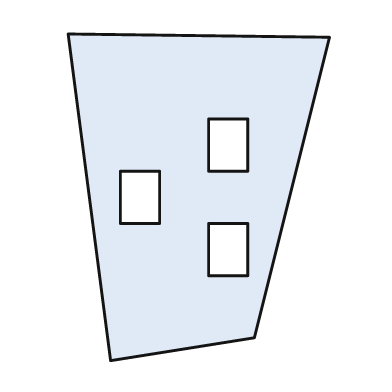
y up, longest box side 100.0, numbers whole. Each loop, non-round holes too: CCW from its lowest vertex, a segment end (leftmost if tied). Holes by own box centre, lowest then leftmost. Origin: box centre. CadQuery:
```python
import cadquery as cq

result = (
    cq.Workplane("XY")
    .moveTo(-27.0, -50.0)
    .lineTo(17.0, -43.0)
    .lineTo(40.0, 49.0)
    .lineTo(-40.0, 50.0)
    .close()
    .moveTo(3.0, -24.0)
    .lineTo(15.0, -24.0)
    .lineTo(15.0, -8.0)
    .lineTo(3.0, -8.0)
    .close()
    .moveTo(-24.0, -8.0)
    .lineTo(-12.0, -8.0)
    .lineTo(-12.0, 8.0)
    .lineTo(-24.0, 8.0)
    .close()
    .moveTo(3.0, 8.0)
    .lineTo(15.0, 8.0)
    .lineTo(15.0, 24.0)
    .lineTo(3.0, 24.0)
    .close()
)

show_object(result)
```